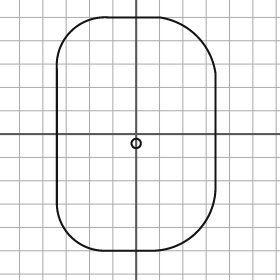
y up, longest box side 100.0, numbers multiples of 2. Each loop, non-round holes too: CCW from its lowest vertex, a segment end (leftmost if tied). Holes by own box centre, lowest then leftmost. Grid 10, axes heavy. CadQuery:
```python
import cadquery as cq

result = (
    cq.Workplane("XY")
    .moveTo(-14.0, -50.0)
    .lineTo(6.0, -50.0)
    .threePointArc((26.0, -42.0), (34.0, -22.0))
    .lineTo(34.0, 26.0)
    .threePointArc((26.0, 42.0), (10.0, 50.0))
    .lineTo(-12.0, 50.0)
    .threePointArc((-28.0, 44.0), (-34.0, 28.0))
    .lineTo(-34.0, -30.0)
    .threePointArc((-28.0, -44.0), (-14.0, -50.0))
    .close()
    .moveTo(0.0, -4.0)
    .circle(2.0)
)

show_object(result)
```